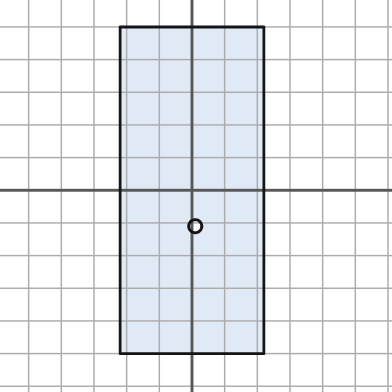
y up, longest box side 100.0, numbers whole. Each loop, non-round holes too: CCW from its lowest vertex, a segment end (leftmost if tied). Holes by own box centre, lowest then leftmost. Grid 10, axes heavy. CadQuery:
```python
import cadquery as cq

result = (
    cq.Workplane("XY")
    .moveTo(-22.0, -50.0)
    .lineTo(22.0, -50.0)
    .lineTo(22.0, 50.0)
    .lineTo(-22.0, 50.0)
    .close()
    .moveTo(1.0, -11.0)
    .circle(2.0)
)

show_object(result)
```